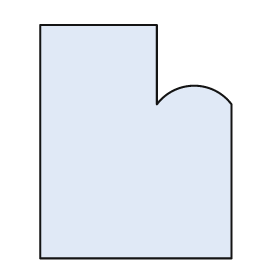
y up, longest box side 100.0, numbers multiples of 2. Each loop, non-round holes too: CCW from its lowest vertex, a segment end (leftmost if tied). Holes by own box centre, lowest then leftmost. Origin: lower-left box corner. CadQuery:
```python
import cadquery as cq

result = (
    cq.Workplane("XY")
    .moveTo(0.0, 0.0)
    .lineTo(82.0, 0.0)
    .lineTo(82.0, 66.0)
    .threePointArc((66.0, 74.0), (50.0, 66.0))
    .lineTo(50.0, 100.0)
    .lineTo(0.0, 100.0)
    .close()
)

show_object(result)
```